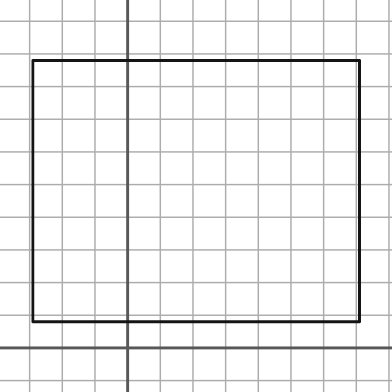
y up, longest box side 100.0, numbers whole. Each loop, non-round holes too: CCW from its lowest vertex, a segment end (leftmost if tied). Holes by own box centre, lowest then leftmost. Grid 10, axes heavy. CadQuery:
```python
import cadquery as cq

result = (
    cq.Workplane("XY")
    .moveTo(-29.0, 8.0)
    .lineTo(71.0, 8.0)
    .lineTo(71.0, 88.0)
    .lineTo(-29.0, 88.0)
    .close()
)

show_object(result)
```